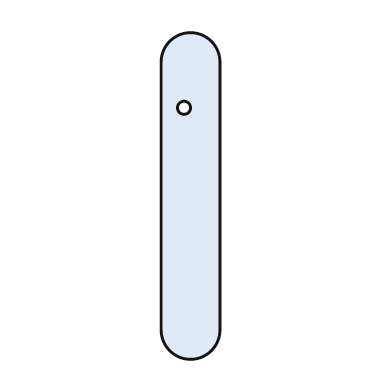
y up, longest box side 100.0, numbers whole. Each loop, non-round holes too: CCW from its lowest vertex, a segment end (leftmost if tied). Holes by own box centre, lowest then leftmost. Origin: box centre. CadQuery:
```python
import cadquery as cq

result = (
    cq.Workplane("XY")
    .moveTo(-9.0, -41.0)
    .threePointArc((0.0, -50.0), (9.0, -41.0))
    .lineTo(9.0, 41.0)
    .threePointArc((0.0, 50.0), (-9.0, 41.0))
    .close()
    .moveTo(-2.0, 27.0)
    .circle(2.0)
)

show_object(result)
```